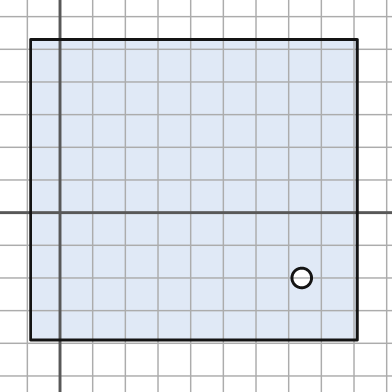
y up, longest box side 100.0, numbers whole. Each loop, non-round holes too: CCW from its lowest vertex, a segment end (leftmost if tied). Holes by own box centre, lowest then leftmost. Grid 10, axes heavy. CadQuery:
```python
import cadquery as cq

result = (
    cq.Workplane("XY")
    .moveTo(-9.0, -39.0)
    .lineTo(91.0, -39.0)
    .lineTo(91.0, 53.0)
    .lineTo(-9.0, 53.0)
    .close()
    .moveTo(74.0, -20.0)
    .circle(3.0)
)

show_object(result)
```